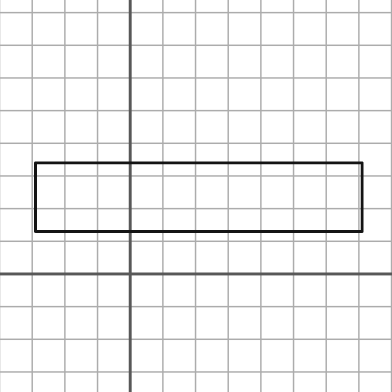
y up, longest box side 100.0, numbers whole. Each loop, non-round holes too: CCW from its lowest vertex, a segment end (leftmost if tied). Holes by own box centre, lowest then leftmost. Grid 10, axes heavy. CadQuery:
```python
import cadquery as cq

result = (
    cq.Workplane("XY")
    .moveTo(-29.0, 13.0)
    .lineTo(71.0, 13.0)
    .lineTo(71.0, 34.0)
    .lineTo(-29.0, 34.0)
    .close()
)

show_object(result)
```